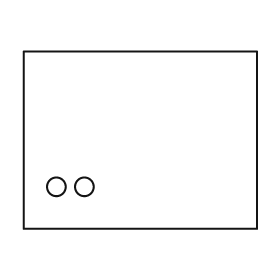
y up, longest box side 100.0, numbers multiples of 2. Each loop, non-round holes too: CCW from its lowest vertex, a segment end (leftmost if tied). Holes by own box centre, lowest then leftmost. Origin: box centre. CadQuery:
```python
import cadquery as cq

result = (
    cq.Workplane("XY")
    .moveTo(-50.0, -38.0)
    .lineTo(50.0, -38.0)
    .lineTo(50.0, 38.0)
    .lineTo(-50.0, 38.0)
    .close()
    .moveTo(-36.0, -20.0)
    .circle(4.0)
    .moveTo(-24.0, -20.0)
    .circle(4.0)
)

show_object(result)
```